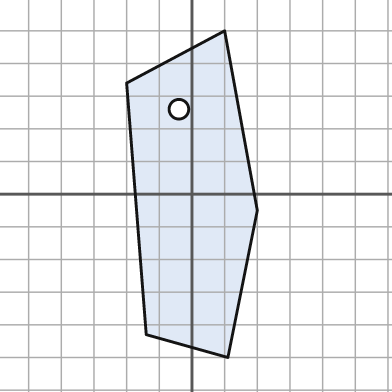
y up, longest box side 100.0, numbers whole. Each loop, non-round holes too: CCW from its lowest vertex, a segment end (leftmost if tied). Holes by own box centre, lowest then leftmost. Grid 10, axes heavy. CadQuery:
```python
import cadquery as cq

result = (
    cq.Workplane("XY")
    .moveTo(11.0, -50.0)
    .lineTo(20.0, -5.0)
    .lineTo(10.0, 50.0)
    .lineTo(-20.0, 34.0)
    .lineTo(-14.0, -43.0)
    .close()
    .moveTo(-4.0, 26.0)
    .circle(3.0)
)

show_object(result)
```